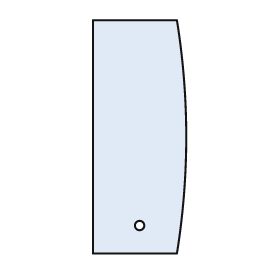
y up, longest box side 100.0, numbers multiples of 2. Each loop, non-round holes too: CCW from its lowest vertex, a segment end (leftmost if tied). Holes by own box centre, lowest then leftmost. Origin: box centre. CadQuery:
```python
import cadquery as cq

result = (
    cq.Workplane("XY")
    .moveTo(-20.0, -50.0)
    .lineTo(16.0, -50.0)
    .threePointArc((20.0, 0.0), (16.0, 50.0))
    .lineTo(-20.0, 50.0)
    .close()
    .moveTo(0.0, -38.0)
    .circle(2.0)
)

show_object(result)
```